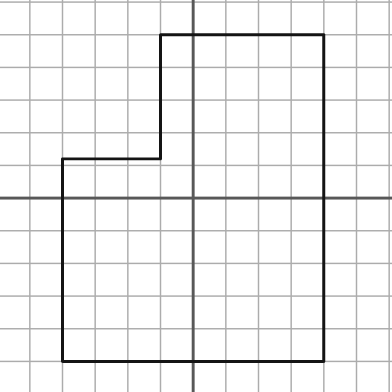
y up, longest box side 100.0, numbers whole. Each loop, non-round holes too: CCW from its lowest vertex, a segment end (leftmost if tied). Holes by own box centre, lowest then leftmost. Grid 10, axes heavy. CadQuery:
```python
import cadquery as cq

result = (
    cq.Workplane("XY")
    .moveTo(-40.0, -50.0)
    .lineTo(40.0, -50.0)
    .lineTo(40.0, 50.0)
    .lineTo(-10.0, 50.0)
    .lineTo(-10.0, 12.0)
    .lineTo(-40.0, 12.0)
    .close()
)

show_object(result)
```